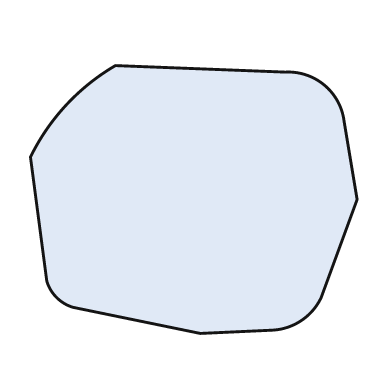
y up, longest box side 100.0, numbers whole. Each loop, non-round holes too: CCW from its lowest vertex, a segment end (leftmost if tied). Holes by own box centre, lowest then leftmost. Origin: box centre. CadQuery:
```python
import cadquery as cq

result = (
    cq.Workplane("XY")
    .moveTo(2.0, -41.0)
    .lineTo(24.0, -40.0)
    .threePointArc((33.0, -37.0), (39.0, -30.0))
    .lineTo(50.0, 0.0)
    .lineTo(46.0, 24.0)
    .threePointArc((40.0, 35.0), (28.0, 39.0))
    .lineTo(-24.0, 41.0)
    .threePointArc((-39.0, 29.0), (-50.0, 13.0))
    .lineTo(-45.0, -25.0)
    .threePointArc((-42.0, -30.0), (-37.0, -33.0))
    .close()
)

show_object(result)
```